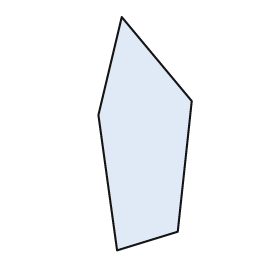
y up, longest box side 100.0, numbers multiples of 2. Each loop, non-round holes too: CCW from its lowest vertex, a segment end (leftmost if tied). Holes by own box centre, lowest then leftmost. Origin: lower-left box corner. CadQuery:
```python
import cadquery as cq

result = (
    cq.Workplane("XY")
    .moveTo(8.0, 0.0)
    .lineTo(34.0, 8.0)
    .lineTo(40.0, 64.0)
    .lineTo(10.0, 100.0)
    .lineTo(0.0, 58.0)
    .close()
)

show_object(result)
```